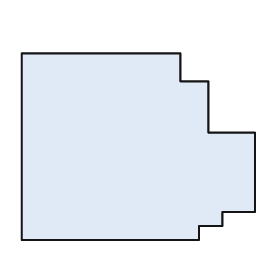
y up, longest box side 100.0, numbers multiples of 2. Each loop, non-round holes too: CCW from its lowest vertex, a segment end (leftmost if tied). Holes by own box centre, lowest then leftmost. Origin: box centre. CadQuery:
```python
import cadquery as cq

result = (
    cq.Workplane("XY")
    .moveTo(-50.0, -40.0)
    .lineTo(26.0, -40.0)
    .lineTo(26.0, -34.0)
    .lineTo(36.0, -34.0)
    .lineTo(36.0, -28.0)
    .lineTo(50.0, -28.0)
    .lineTo(50.0, 6.0)
    .lineTo(30.0, 6.0)
    .lineTo(30.0, 28.0)
    .lineTo(18.0, 28.0)
    .lineTo(18.0, 40.0)
    .lineTo(-50.0, 40.0)
    .close()
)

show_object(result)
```